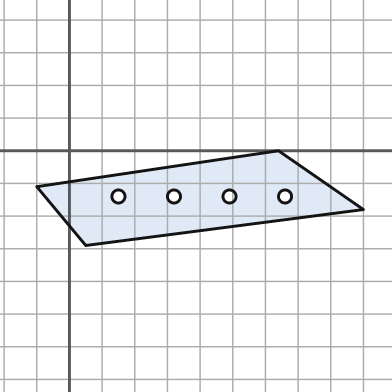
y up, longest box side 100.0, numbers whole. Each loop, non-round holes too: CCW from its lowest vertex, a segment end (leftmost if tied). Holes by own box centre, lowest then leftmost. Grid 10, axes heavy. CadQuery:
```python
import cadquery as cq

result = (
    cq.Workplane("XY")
    .moveTo(5.0, -29.0)
    .lineTo(90.0, -18.0)
    .lineTo(64.0, 0.0)
    .lineTo(-10.0, -11.0)
    .close()
    .moveTo(15.0, -14.0)
    .circle(2.0)
    .moveTo(32.0, -14.0)
    .circle(2.0)
    .moveTo(49.0, -14.0)
    .circle(2.0)
    .moveTo(66.0, -14.0)
    .circle(2.0)
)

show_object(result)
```